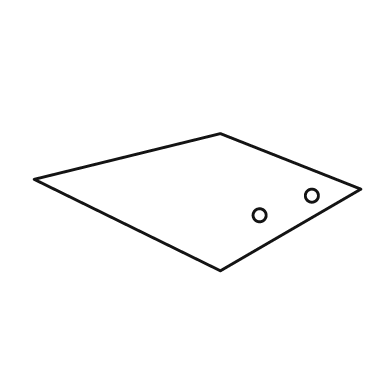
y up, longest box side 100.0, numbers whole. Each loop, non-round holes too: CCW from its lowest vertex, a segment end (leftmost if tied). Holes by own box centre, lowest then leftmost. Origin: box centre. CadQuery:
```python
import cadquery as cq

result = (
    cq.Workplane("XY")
    .moveTo(7.0, -21.0)
    .lineTo(50.0, 4.0)
    .lineTo(7.0, 21.0)
    .lineTo(-50.0, 7.0)
    .close()
    .moveTo(19.0, -4.0)
    .circle(2.0)
    .moveTo(35.0, 2.0)
    .circle(2.0)
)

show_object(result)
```